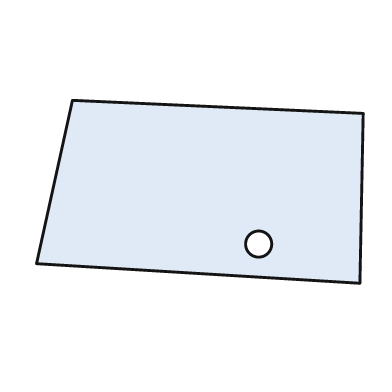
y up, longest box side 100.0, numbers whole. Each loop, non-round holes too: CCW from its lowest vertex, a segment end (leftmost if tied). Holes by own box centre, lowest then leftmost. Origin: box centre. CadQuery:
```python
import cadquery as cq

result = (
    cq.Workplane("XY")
    .moveTo(49.0, -28.0)
    .lineTo(50.0, 24.0)
    .lineTo(-39.0, 28.0)
    .lineTo(-50.0, -22.0)
    .close()
    .moveTo(18.0, -16.0)
    .circle(4.0)
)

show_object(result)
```